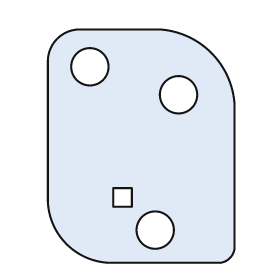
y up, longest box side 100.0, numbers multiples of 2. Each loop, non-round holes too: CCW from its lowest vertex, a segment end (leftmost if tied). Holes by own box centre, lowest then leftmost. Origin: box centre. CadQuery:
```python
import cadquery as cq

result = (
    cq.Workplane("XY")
    .moveTo(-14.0, -50.0)
    .lineTo(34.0, -50.0)
    .threePointArc((38.0, -48.0), (40.0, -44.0))
    .lineTo(40.0, 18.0)
    .threePointArc((30.0, 40.0), (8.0, 50.0))
    .lineTo(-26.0, 50.0)
    .threePointArc((-36.0, 46.0), (-40.0, 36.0))
    .lineTo(-40.0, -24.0)
    .threePointArc((-32.0, -42.0), (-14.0, -50.0))
    .close()
    .moveTo(6.0, -36.0)
    .circle(8.0)
    .moveTo(-12.0, -26.0)
    .lineTo(-4.0, -26.0)
    .lineTo(-4.0, -18.0)
    .lineTo(-12.0, -18.0)
    .close()
    .moveTo(16.0, 22.0)
    .circle(8.0)
    .moveTo(-22.0, 34.0)
    .circle(8.0)
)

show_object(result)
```